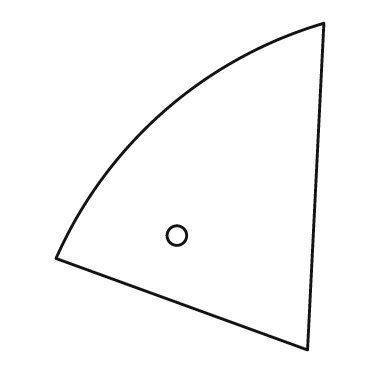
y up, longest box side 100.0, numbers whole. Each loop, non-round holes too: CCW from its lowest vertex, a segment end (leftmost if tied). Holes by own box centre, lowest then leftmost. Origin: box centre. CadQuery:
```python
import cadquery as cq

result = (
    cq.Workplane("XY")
    .moveTo(36.0, -50.0)
    .lineTo(41.0, 50.0)
    .threePointArc((-8.0, 23.0), (-41.0, -22.0))
    .close()
    .moveTo(-4.0, -15.0)
    .circle(3.0)
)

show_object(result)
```